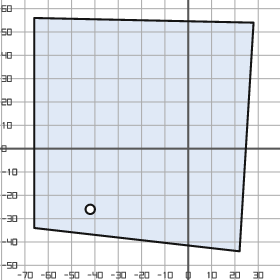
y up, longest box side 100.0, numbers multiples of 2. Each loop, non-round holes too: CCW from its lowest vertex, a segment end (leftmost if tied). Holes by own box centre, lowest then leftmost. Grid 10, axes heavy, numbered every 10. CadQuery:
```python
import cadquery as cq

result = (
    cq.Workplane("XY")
    .moveTo(22.0, -44.0)
    .lineTo(28.0, 54.0)
    .lineTo(-66.0, 56.0)
    .lineTo(-66.0, -34.0)
    .close()
    .moveTo(-42.0, -26.0)
    .circle(2.0)
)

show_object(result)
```